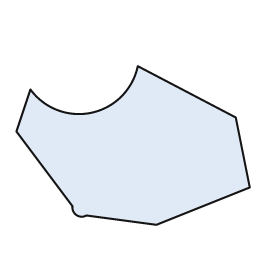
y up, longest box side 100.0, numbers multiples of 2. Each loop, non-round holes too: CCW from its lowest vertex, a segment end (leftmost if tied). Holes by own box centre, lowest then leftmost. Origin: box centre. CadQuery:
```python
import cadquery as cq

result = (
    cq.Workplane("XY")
    .moveTo(10.0, -34.0)
    .lineTo(50.0, -18.0)
    .lineTo(44.0, 12.0)
    .lineTo(2.0, 34.0)
    .threePointArc((-18.0, 14.0), (-44.0, 24.0))
    .lineTo(-50.0, 6.0)
    .lineTo(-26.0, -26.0)
    .threePointArc((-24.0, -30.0), (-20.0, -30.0))
    .close()
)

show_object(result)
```